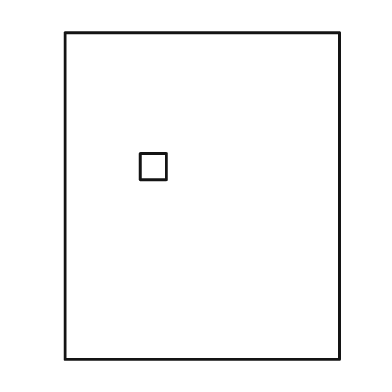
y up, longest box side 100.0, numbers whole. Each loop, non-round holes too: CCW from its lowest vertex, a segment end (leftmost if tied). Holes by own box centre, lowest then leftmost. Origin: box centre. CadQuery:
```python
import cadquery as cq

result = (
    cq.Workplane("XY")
    .moveTo(-42.0, -50.0)
    .lineTo(42.0, -50.0)
    .lineTo(42.0, 50.0)
    .lineTo(-42.0, 50.0)
    .close()
    .moveTo(-19.0, 5.0)
    .lineTo(-11.0, 5.0)
    .lineTo(-11.0, 13.0)
    .lineTo(-19.0, 13.0)
    .close()
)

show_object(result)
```